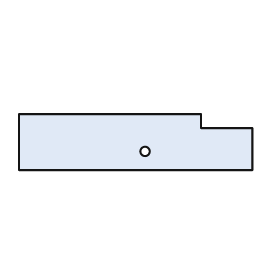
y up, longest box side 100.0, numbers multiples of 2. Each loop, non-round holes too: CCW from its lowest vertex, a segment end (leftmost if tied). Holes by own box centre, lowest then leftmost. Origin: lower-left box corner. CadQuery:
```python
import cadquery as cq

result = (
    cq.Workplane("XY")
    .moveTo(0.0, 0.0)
    .lineTo(100.0, 0.0)
    .lineTo(100.0, 18.0)
    .lineTo(78.0, 18.0)
    .lineTo(78.0, 24.0)
    .lineTo(0.0, 24.0)
    .close()
    .moveTo(54.0, 8.0)
    .circle(2.0)
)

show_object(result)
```